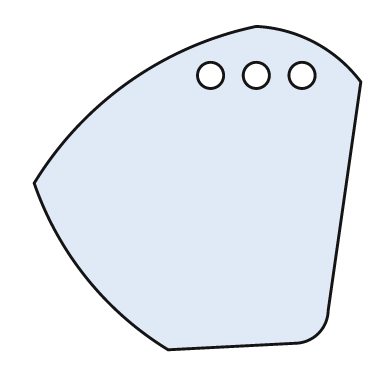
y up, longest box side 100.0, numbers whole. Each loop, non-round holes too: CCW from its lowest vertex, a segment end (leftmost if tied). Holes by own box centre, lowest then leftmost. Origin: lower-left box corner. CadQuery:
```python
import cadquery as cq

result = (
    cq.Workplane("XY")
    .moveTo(41.0, 0.0)
    .lineTo(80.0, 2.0)
    .threePointArc((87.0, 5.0), (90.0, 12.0))
    .lineTo(100.0, 82.0)
    .threePointArc((86.0, 94.0), (68.0, 99.0))
    .threePointArc((29.0, 82.0), (0.0, 51.0))
    .threePointArc((16.0, 22.0), (41.0, 0.0))
    .close()
    .moveTo(54.0, 84.0)
    .circle(4.0)
    .moveTo(68.0, 84.0)
    .circle(4.0)
    .moveTo(82.0, 84.0)
    .circle(4.0)
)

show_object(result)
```